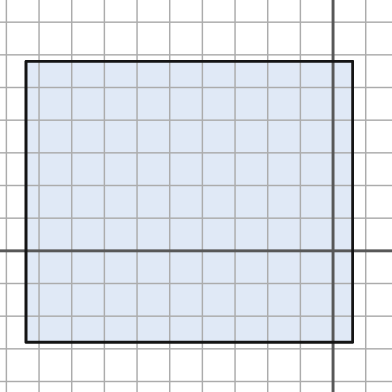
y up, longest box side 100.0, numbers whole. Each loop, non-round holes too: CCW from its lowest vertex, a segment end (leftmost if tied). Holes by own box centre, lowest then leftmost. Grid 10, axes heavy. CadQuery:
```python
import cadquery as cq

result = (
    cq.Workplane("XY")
    .moveTo(-94.0, -28.0)
    .lineTo(6.0, -28.0)
    .lineTo(6.0, 58.0)
    .lineTo(-94.0, 58.0)
    .close()
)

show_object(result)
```